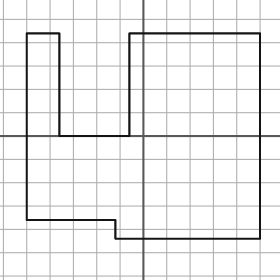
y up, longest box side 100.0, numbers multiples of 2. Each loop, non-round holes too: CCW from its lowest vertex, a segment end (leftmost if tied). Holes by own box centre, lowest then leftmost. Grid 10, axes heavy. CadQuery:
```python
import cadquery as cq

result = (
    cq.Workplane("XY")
    .moveTo(-12.0, -44.0)
    .lineTo(50.0, -44.0)
    .lineTo(50.0, 44.0)
    .lineTo(-6.0, 44.0)
    .lineTo(-6.0, 0.0)
    .lineTo(-36.0, 0.0)
    .lineTo(-36.0, 44.0)
    .lineTo(-50.0, 44.0)
    .lineTo(-50.0, -36.0)
    .lineTo(-12.0, -36.0)
    .close()
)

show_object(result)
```